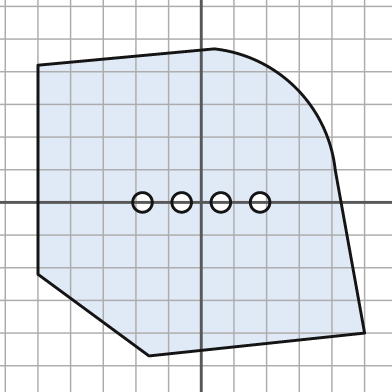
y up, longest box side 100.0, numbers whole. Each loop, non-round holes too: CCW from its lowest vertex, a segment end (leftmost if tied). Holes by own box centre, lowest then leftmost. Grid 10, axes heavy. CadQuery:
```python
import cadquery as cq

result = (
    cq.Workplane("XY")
    .moveTo(-16.0, -47.0)
    .lineTo(50.0, -40.0)
    .lineTo(41.0, 10.0)
    .threePointArc((29.0, 35.0), (4.0, 47.0))
    .lineTo(-50.0, 42.0)
    .lineTo(-50.0, -22.0)
    .close()
    .moveTo(-18.0, 0.0)
    .circle(3.0)
    .moveTo(-6.0, 0.0)
    .circle(3.0)
    .moveTo(6.0, 0.0)
    .circle(3.0)
    .moveTo(18.0, 0.0)
    .circle(3.0)
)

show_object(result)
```